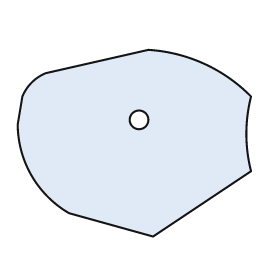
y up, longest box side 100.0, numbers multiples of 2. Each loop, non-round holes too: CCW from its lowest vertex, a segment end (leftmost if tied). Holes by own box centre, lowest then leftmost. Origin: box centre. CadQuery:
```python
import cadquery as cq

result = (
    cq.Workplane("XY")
    .moveTo(8.0, -40.0)
    .lineTo(50.0, -12.0)
    .threePointArc((48.0, 4.0), (50.0, 20.0))
    .threePointArc((30.0, 34.0), (6.0, 40.0))
    .lineTo(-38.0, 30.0)
    .threePointArc((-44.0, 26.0), (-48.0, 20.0))
    .lineTo(-50.0, 8.0)
    .threePointArc((-44.0, -14.0), (-28.0, -30.0))
    .close()
    .moveTo(2.0, 10.0)
    .circle(4.0)
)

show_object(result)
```